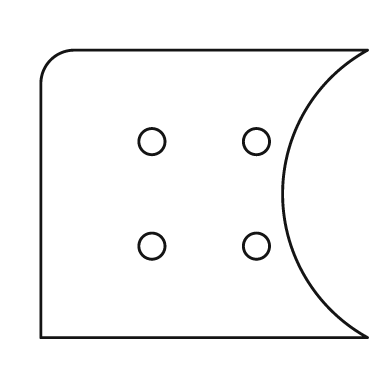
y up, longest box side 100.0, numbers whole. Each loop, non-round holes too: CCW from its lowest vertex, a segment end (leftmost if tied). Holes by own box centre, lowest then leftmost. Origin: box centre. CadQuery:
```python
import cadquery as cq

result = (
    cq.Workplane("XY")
    .moveTo(-50.0, -44.0)
    .lineTo(50.0, -44.0)
    .threePointArc((24.0, 0.0), (50.0, 44.0))
    .lineTo(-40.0, 44.0)
    .threePointArc((-47.0, 41.0), (-50.0, 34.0))
    .close()
    .moveTo(-16.0, -16.0)
    .circle(4.0)
    .moveTo(16.0, -16.0)
    .circle(4.0)
    .moveTo(-16.0, 16.0)
    .circle(4.0)
    .moveTo(16.0, 16.0)
    .circle(4.0)
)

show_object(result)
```